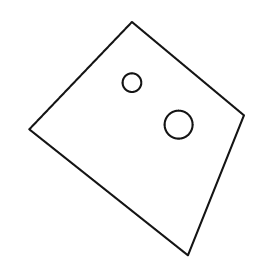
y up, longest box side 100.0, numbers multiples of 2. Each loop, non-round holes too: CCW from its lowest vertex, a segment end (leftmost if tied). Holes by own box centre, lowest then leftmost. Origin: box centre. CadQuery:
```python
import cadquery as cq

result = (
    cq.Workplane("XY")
    .moveTo(22.0, -50.0)
    .lineTo(46.0, 10.0)
    .lineTo(-2.0, 50.0)
    .lineTo(-46.0, 4.0)
    .close()
    .moveTo(18.0, 6.0)
    .circle(6.0)
    .moveTo(-2.0, 24.0)
    .circle(4.0)
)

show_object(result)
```